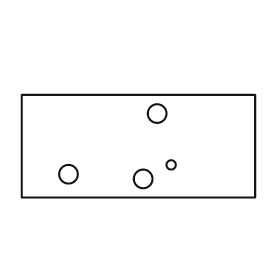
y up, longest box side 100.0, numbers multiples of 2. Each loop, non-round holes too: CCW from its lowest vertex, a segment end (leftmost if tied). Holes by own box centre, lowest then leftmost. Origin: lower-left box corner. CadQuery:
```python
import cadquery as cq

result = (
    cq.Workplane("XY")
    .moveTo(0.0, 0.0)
    .lineTo(100.0, 0.0)
    .lineTo(100.0, 44.0)
    .lineTo(0.0, 44.0)
    .close()
    .moveTo(52.0, 8.0)
    .circle(4.0)
    .moveTo(20.0, 10.0)
    .circle(4.0)
    .moveTo(64.0, 14.0)
    .circle(2.0)
    .moveTo(58.0, 36.0)
    .circle(4.0)
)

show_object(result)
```